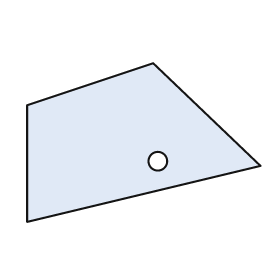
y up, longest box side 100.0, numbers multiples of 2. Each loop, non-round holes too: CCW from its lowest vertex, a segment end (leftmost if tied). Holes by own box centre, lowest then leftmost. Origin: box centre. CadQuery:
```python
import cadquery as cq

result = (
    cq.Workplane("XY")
    .moveTo(-50.0, -34.0)
    .lineTo(50.0, -10.0)
    .lineTo(4.0, 34.0)
    .lineTo(-50.0, 16.0)
    .close()
    .moveTo(6.0, -8.0)
    .circle(4.0)
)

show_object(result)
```